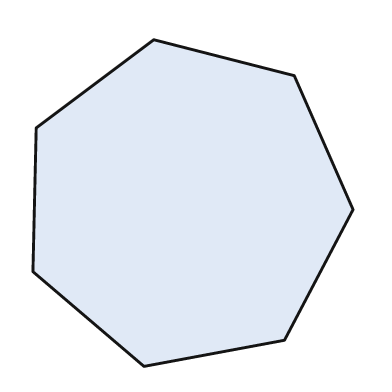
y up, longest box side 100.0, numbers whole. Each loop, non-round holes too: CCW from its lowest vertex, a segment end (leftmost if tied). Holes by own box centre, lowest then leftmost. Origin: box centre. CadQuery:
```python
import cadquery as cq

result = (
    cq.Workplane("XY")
    .moveTo(-15.0, -50.0)
    .lineTo(28.0, -42.0)
    .lineTo(49.0, -2.0)
    .lineTo(31.0, 39.0)
    .lineTo(-12.0, 50.0)
    .lineTo(-48.0, 23.0)
    .lineTo(-49.0, -21.0)
    .close()
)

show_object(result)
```